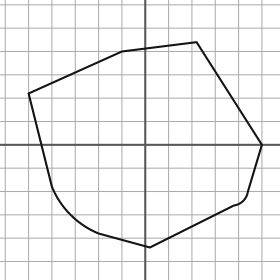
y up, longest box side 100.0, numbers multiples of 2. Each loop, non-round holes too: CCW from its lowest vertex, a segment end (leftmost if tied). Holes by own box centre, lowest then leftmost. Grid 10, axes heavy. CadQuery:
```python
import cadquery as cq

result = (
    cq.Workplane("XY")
    .moveTo(2.0, -44.0)
    .lineTo(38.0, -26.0)
    .threePointArc((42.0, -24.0), (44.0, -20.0))
    .lineTo(50.0, 0.0)
    .lineTo(22.0, 44.0)
    .lineTo(-10.0, 40.0)
    .lineTo(-50.0, 22.0)
    .lineTo(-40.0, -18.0)
    .threePointArc((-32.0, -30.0), (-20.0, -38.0))
    .close()
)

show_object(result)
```